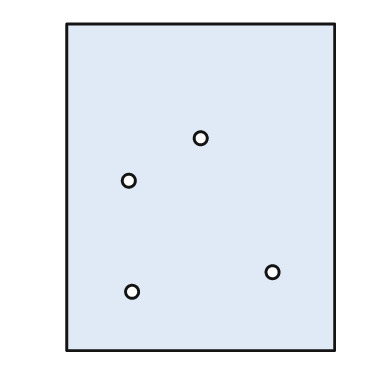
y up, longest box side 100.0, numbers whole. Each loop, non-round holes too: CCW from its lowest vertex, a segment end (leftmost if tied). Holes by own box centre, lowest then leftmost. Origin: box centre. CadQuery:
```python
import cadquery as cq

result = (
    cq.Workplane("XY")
    .moveTo(-41.0, -50.0)
    .lineTo(41.0, -50.0)
    .lineTo(41.0, 50.0)
    .lineTo(-41.0, 50.0)
    .close()
    .moveTo(-21.0, -32.0)
    .circle(2.0)
    .moveTo(22.0, -26.0)
    .circle(2.0)
    .moveTo(-22.0, 2.0)
    .circle(2.0)
    .moveTo(0.0, 15.0)
    .circle(2.0)
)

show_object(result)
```